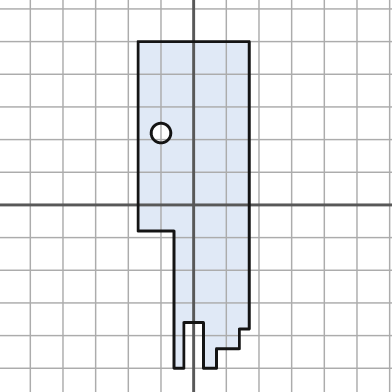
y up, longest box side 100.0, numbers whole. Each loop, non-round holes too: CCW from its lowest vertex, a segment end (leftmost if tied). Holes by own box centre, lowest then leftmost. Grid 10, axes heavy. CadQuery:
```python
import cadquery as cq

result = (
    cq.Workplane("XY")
    .moveTo(-6.0, -50.0)
    .lineTo(-3.0, -50.0)
    .lineTo(-3.0, -36.0)
    .lineTo(3.0, -36.0)
    .lineTo(3.0, -50.0)
    .lineTo(7.0, -50.0)
    .lineTo(7.0, -44.0)
    .lineTo(14.0, -44.0)
    .lineTo(14.0, -38.0)
    .lineTo(17.0, -38.0)
    .lineTo(17.0, 50.0)
    .lineTo(-17.0, 50.0)
    .lineTo(-17.0, -8.0)
    .lineTo(-6.0, -8.0)
    .close()
    .moveTo(-10.0, 22.0)
    .circle(3.0)
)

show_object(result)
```